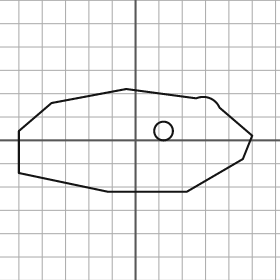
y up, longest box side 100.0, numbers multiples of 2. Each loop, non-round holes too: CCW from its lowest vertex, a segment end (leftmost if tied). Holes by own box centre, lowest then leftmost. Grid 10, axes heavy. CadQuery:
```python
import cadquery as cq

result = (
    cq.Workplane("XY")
    .moveTo(-12.0, -22.0)
    .lineTo(22.0, -22.0)
    .lineTo(46.0, -8.0)
    .lineTo(50.0, 2.0)
    .lineTo(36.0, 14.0)
    .threePointArc((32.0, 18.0), (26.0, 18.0))
    .lineTo(-4.0, 22.0)
    .lineTo(-36.0, 16.0)
    .lineTo(-50.0, 4.0)
    .lineTo(-50.0, -14.0)
    .close()
    .moveTo(12.0, 4.0)
    .circle(4.0)
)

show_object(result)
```